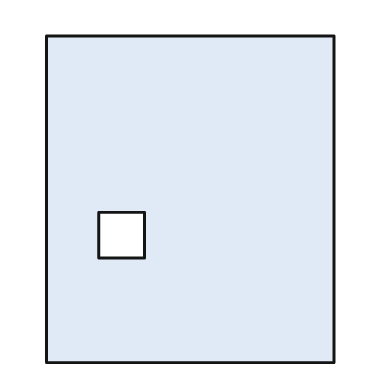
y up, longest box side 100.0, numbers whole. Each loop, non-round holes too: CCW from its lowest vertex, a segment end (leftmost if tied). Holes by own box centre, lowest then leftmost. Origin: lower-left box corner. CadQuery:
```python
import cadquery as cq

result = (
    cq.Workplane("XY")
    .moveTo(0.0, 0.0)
    .lineTo(88.0, 0.0)
    .lineTo(88.0, 100.0)
    .lineTo(0.0, 100.0)
    .close()
    .moveTo(16.0, 32.0)
    .lineTo(30.0, 32.0)
    .lineTo(30.0, 46.0)
    .lineTo(16.0, 46.0)
    .close()
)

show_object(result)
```